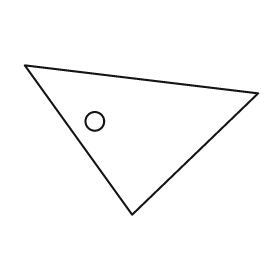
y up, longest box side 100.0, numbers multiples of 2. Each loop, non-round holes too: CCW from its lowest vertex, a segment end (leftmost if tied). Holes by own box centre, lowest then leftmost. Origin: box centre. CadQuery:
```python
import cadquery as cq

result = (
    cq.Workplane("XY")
    .moveTo(-4.0, -32.0)
    .lineTo(50.0, 20.0)
    .lineTo(-50.0, 32.0)
    .close()
    .moveTo(-20.0, 8.0)
    .circle(4.0)
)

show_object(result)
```